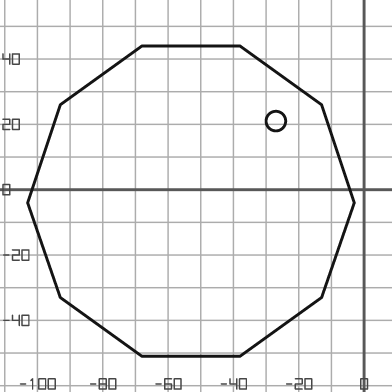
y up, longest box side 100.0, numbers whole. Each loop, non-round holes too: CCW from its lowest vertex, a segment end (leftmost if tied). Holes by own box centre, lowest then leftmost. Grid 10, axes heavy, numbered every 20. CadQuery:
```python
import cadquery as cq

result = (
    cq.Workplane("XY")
    .moveTo(-68.0, -51.0)
    .lineTo(-38.0, -51.0)
    .lineTo(-13.0, -33.0)
    .lineTo(-3.0, -4.0)
    .lineTo(-13.0, 26.0)
    .lineTo(-38.0, 44.0)
    .lineTo(-68.0, 44.0)
    .lineTo(-93.0, 26.0)
    .lineTo(-103.0, -4.0)
    .lineTo(-93.0, -33.0)
    .close()
    .moveTo(-27.0, 21.0)
    .circle(3.0)
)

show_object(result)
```